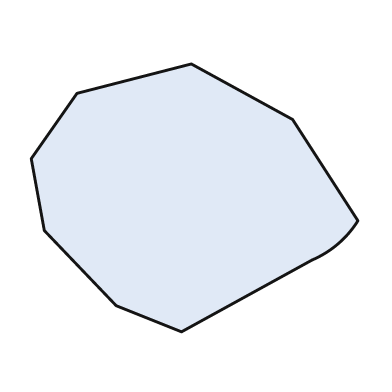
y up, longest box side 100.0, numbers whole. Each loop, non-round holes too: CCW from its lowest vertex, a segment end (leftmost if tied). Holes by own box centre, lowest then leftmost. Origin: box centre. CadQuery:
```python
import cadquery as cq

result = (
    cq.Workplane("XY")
    .moveTo(-4.0, -41.0)
    .lineTo(36.0, -19.0)
    .threePointArc((44.0, -14.0), (50.0, -7.0))
    .lineTo(30.0, 24.0)
    .lineTo(-1.0, 41.0)
    .lineTo(-36.0, 32.0)
    .lineTo(-50.0, 12.0)
    .lineTo(-46.0, -10.0)
    .lineTo(-24.0, -33.0)
    .close()
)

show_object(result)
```